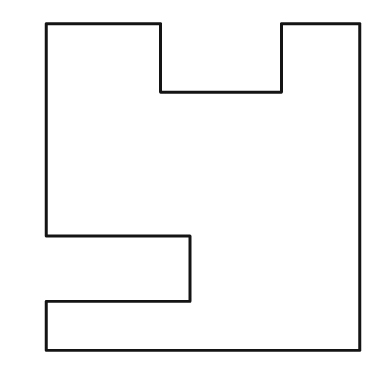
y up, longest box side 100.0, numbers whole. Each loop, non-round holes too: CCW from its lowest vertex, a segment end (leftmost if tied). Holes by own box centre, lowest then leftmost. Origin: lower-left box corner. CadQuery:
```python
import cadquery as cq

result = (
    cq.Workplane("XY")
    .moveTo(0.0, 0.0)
    .lineTo(96.0, 0.0)
    .lineTo(96.0, 100.0)
    .lineTo(72.0, 100.0)
    .lineTo(72.0, 79.0)
    .lineTo(35.0, 79.0)
    .lineTo(35.0, 100.0)
    .lineTo(0.0, 100.0)
    .lineTo(0.0, 35.0)
    .lineTo(44.0, 35.0)
    .lineTo(44.0, 15.0)
    .lineTo(0.0, 15.0)
    .close()
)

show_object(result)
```